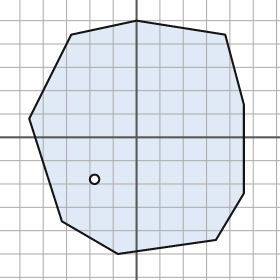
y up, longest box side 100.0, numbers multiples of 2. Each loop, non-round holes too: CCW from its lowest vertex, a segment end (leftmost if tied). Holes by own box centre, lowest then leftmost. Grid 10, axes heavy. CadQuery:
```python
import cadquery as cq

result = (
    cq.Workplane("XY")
    .moveTo(-8.0, -50.0)
    .lineTo(34.0, -44.0)
    .lineTo(46.0, -24.0)
    .lineTo(46.0, 14.0)
    .lineTo(38.0, 44.0)
    .lineTo(0.0, 50.0)
    .lineTo(-28.0, 44.0)
    .lineTo(-46.0, 8.0)
    .lineTo(-32.0, -36.0)
    .close()
    .moveTo(-18.0, -18.0)
    .circle(2.0)
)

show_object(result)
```